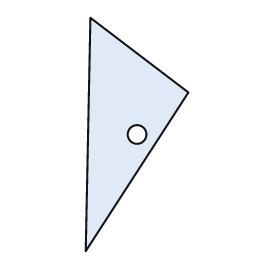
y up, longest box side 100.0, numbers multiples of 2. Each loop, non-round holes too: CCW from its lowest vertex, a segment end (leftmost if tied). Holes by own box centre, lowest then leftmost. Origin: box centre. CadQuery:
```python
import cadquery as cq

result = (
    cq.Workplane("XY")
    .moveTo(-22.0, -50.0)
    .lineTo(22.0, 18.0)
    .lineTo(-20.0, 50.0)
    .close()
    .moveTo(0.0, 0.0)
    .circle(4.0)
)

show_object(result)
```